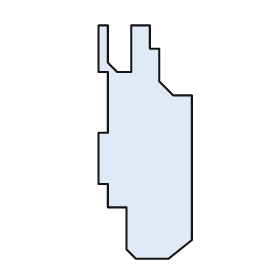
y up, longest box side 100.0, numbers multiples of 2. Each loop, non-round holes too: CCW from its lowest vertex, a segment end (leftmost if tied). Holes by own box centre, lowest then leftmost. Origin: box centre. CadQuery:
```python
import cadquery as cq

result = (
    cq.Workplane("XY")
    .moveTo(-4.0, -50.0)
    .lineTo(10.0, -50.0)
    .lineTo(20.0, -42.0)
    .lineTo(20.0, 20.0)
    .lineTo(12.0, 20.0)
    .lineTo(6.0, 26.0)
    .lineTo(6.0, 40.0)
    .lineTo(2.0, 40.0)
    .lineTo(2.0, 50.0)
    .lineTo(-6.0, 50.0)
    .lineTo(-6.0, 30.0)
    .lineTo(-12.0, 30.0)
    .lineTo(-16.0, 34.0)
    .lineTo(-16.0, 50.0)
    .lineTo(-20.0, 50.0)
    .lineTo(-20.0, 30.0)
    .lineTo(-16.0, 30.0)
    .lineTo(-16.0, 4.0)
    .lineTo(-20.0, 4.0)
    .lineTo(-20.0, -18.0)
    .lineTo(-16.0, -18.0)
    .lineTo(-16.0, -28.0)
    .lineTo(-8.0, -28.0)
    .lineTo(-8.0, -46.0)
    .close()
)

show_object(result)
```